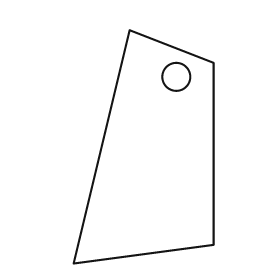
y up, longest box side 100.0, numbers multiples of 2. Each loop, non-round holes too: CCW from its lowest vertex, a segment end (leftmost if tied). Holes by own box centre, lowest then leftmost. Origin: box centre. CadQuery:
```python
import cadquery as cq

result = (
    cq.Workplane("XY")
    .moveTo(-30.0, -50.0)
    .lineTo(30.0, -42.0)
    .lineTo(30.0, 36.0)
    .lineTo(-6.0, 50.0)
    .close()
    .moveTo(14.0, 30.0)
    .circle(6.0)
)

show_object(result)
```